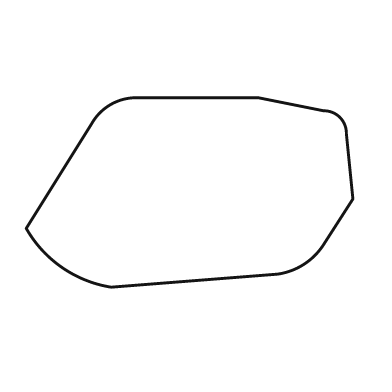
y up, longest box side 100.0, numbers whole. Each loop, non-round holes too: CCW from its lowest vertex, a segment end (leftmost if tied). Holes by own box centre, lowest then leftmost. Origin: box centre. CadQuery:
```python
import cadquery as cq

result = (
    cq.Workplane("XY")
    .moveTo(-24.0, -29.0)
    .lineTo(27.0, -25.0)
    .threePointArc((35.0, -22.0), (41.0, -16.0))
    .lineTo(50.0, -2.0)
    .lineTo(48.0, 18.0)
    .threePointArc((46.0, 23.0), (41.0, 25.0))
    .lineTo(21.0, 29.0)
    .lineTo(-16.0, 29.0)
    .threePointArc((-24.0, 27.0), (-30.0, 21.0))
    .lineTo(-50.0, -11.0)
    .threePointArc((-39.0, -23.0), (-24.0, -29.0))
    .close()
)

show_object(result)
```